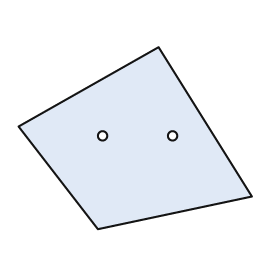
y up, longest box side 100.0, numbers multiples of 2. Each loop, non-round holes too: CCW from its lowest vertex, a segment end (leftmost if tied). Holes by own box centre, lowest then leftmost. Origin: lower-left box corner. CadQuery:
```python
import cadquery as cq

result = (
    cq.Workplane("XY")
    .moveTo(34.0, 0.0)
    .lineTo(100.0, 14.0)
    .lineTo(60.0, 78.0)
    .lineTo(0.0, 44.0)
    .close()
    .moveTo(36.0, 40.0)
    .circle(2.0)
    .moveTo(66.0, 40.0)
    .circle(2.0)
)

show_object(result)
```